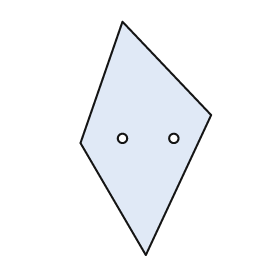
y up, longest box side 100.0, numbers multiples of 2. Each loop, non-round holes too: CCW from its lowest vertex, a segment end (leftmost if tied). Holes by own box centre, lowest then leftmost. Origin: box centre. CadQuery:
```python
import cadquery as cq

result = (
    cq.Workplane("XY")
    .moveTo(0.0, -50.0)
    .lineTo(28.0, 10.0)
    .lineTo(-10.0, 50.0)
    .lineTo(-28.0, -2.0)
    .close()
    .moveTo(-10.0, 0.0)
    .circle(2.0)
    .moveTo(12.0, 0.0)
    .circle(2.0)
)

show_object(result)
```